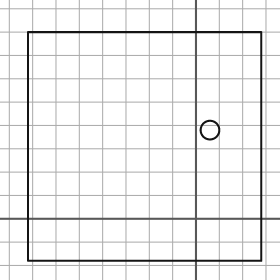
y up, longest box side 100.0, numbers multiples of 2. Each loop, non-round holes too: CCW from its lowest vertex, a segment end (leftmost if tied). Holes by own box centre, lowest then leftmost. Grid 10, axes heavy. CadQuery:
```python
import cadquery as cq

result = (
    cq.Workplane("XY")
    .moveTo(-72.0, -18.0)
    .lineTo(28.0, -18.0)
    .lineTo(28.0, 80.0)
    .lineTo(-72.0, 80.0)
    .close()
    .moveTo(6.0, 38.0)
    .circle(4.0)
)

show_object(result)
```